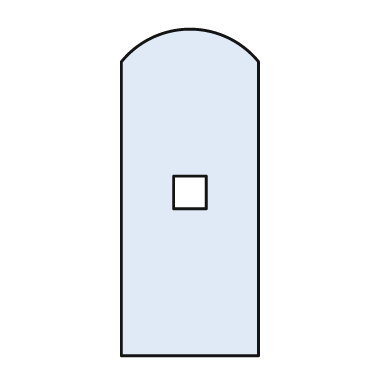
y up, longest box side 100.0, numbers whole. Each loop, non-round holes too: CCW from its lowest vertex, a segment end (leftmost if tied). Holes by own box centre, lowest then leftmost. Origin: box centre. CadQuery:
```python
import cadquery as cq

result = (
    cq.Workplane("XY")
    .moveTo(-21.0, -50.0)
    .lineTo(21.0, -50.0)
    .lineTo(21.0, 40.0)
    .threePointArc((0.0, 50.0), (-21.0, 40.0))
    .close()
    .moveTo(-5.0, -5.0)
    .lineTo(5.0, -5.0)
    .lineTo(5.0, 5.0)
    .lineTo(-5.0, 5.0)
    .close()
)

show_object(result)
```